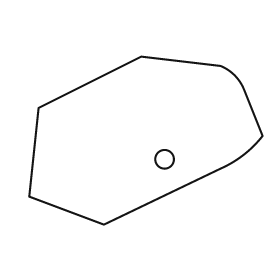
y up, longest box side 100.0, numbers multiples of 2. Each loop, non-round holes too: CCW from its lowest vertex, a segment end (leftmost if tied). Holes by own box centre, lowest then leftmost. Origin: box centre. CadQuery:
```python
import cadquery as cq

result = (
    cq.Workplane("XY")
    .moveTo(-18.0, -36.0)
    .lineTo(32.0, -12.0)
    .threePointArc((42.0, -6.0), (50.0, 2.0))
    .lineTo(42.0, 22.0)
    .threePointArc((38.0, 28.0), (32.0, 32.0))
    .lineTo(-2.0, 36.0)
    .lineTo(-46.0, 14.0)
    .lineTo(-50.0, -24.0)
    .close()
    .moveTo(8.0, -8.0)
    .circle(4.0)
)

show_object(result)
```